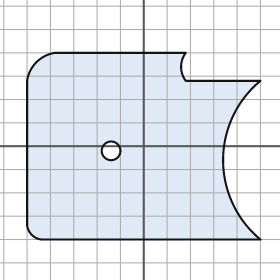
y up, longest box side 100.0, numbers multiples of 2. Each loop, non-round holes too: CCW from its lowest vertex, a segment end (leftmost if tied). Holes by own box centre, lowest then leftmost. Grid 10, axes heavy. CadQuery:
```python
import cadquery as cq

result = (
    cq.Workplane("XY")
    .moveTo(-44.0, -40.0)
    .lineTo(50.0, -40.0)
    .threePointArc((34.0, -6.0), (50.0, 28.0))
    .lineTo(18.0, 28.0)
    .threePointArc((16.0, 34.0), (18.0, 40.0))
    .lineTo(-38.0, 40.0)
    .threePointArc((-46.0, 36.0), (-50.0, 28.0))
    .lineTo(-50.0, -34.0)
    .threePointArc((-48.0, -38.0), (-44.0, -40.0))
    .close()
    .moveTo(-14.0, -2.0)
    .circle(4.0)
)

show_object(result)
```